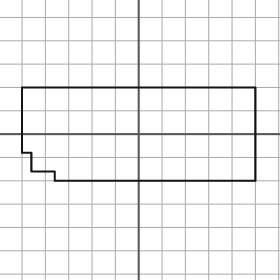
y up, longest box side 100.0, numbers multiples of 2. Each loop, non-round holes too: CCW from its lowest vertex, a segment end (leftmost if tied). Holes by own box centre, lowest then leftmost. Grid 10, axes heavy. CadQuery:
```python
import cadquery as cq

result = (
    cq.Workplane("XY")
    .moveTo(-36.0, -20.0)
    .lineTo(50.0, -20.0)
    .lineTo(50.0, 20.0)
    .lineTo(-50.0, 20.0)
    .lineTo(-50.0, -8.0)
    .lineTo(-46.0, -8.0)
    .lineTo(-46.0, -16.0)
    .lineTo(-36.0, -16.0)
    .close()
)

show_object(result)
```